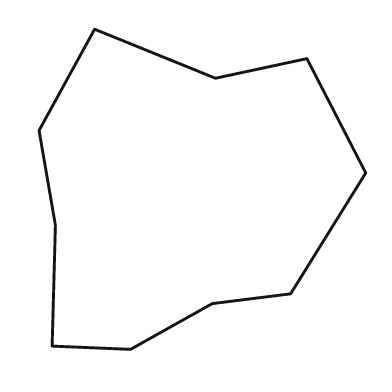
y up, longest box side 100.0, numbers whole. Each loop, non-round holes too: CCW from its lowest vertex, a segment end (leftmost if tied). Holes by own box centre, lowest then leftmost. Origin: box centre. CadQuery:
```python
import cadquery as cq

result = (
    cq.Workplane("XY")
    .moveTo(-22.0, -49.0)
    .lineTo(3.0, -35.0)
    .lineTo(27.0, -32.0)
    .lineTo(50.0, 5.0)
    .lineTo(32.0, 40.0)
    .lineTo(4.0, 34.0)
    .lineTo(-33.0, 49.0)
    .lineTo(-50.0, 18.0)
    .lineTo(-45.0, -11.0)
    .lineTo(-46.0, -48.0)
    .close()
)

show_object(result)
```